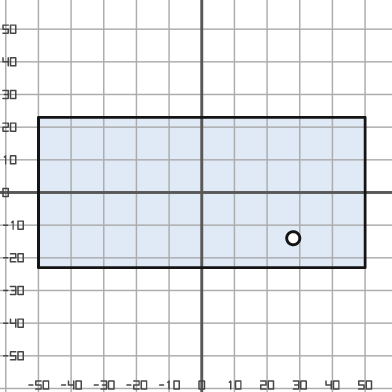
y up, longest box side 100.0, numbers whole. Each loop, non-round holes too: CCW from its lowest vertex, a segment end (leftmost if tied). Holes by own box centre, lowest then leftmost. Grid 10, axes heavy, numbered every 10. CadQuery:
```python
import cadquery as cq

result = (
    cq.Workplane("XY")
    .moveTo(-50.0, -23.0)
    .lineTo(50.0, -23.0)
    .lineTo(50.0, 23.0)
    .lineTo(-50.0, 23.0)
    .close()
    .moveTo(28.0, -14.0)
    .circle(2.0)
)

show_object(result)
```